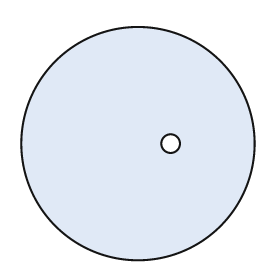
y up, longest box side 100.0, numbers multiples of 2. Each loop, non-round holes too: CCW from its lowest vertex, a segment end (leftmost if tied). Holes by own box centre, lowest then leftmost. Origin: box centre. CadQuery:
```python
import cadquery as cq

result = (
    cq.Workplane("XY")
    .moveTo(0.0, 0.0)
    .circle(50.0)
    .moveTo(14.0, 0.0)
    .circle(4.0)
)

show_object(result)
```